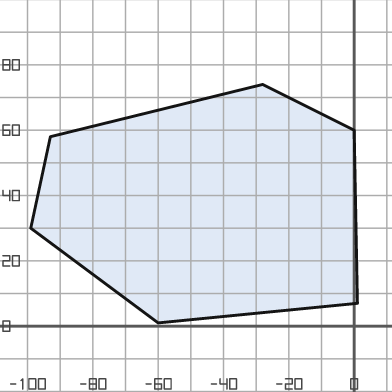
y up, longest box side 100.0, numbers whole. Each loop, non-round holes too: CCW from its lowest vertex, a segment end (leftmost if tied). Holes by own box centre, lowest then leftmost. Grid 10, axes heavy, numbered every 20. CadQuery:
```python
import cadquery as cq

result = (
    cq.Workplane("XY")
    .moveTo(-60.0, 1.0)
    .lineTo(1.0, 7.0)
    .lineTo(0.0, 60.0)
    .lineTo(-28.0, 74.0)
    .lineTo(-93.0, 58.0)
    .lineTo(-99.0, 30.0)
    .close()
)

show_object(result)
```